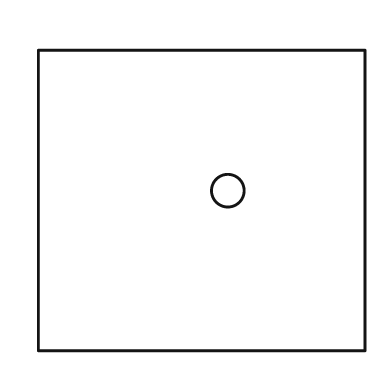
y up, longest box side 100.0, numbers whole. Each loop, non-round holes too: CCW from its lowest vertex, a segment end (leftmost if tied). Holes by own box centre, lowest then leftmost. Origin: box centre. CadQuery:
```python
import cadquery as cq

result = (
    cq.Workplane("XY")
    .moveTo(-50.0, -46.0)
    .lineTo(50.0, -46.0)
    .lineTo(50.0, 46.0)
    .lineTo(-50.0, 46.0)
    .close()
    .moveTo(8.0, 3.0)
    .circle(5.0)
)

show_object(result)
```